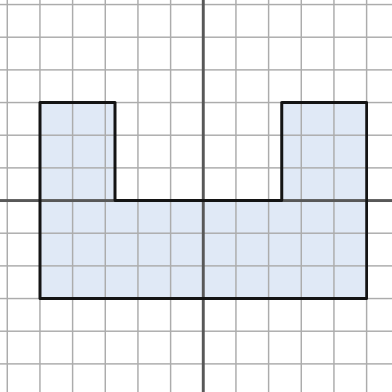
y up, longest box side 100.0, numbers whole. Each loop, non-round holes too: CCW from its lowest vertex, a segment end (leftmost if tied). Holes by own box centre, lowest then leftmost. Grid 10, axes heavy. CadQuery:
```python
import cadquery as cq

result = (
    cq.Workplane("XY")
    .moveTo(-50.0, -30.0)
    .lineTo(50.0, -30.0)
    .lineTo(50.0, 30.0)
    .lineTo(24.0, 30.0)
    .lineTo(24.0, 0.0)
    .lineTo(-27.0, 0.0)
    .lineTo(-27.0, 30.0)
    .lineTo(-50.0, 30.0)
    .close()
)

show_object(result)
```